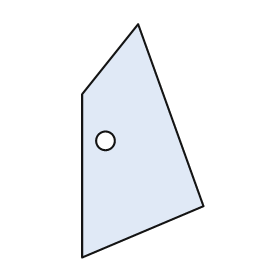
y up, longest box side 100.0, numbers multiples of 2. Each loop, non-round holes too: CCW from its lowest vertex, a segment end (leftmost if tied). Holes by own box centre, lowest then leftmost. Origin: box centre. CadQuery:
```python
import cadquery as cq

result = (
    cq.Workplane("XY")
    .moveTo(-26.0, -50.0)
    .lineTo(26.0, -28.0)
    .lineTo(-2.0, 50.0)
    .lineTo(-26.0, 20.0)
    .close()
    .moveTo(-16.0, 0.0)
    .circle(4.0)
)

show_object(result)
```